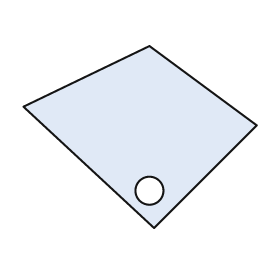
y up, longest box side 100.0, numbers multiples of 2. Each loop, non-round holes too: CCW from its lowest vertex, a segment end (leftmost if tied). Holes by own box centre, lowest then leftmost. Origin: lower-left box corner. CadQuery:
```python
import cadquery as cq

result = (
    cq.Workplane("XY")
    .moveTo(56.0, 0.0)
    .lineTo(100.0, 44.0)
    .lineTo(54.0, 78.0)
    .lineTo(0.0, 52.0)
    .close()
    .moveTo(54.0, 16.0)
    .circle(6.0)
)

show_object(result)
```